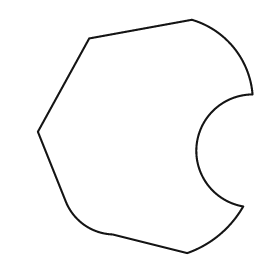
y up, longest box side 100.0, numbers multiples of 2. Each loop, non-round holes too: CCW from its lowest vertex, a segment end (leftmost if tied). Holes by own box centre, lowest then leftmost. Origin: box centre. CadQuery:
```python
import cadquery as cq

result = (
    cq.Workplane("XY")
    .moveTo(18.0, -50.0)
    .threePointArc((32.0, -42.0), (42.0, -30.0))
    .threePointArc((22.0, -4.0), (46.0, 18.0))
    .threePointArc((38.0, 38.0), (20.0, 50.0))
    .lineTo(-24.0, 42.0)
    .lineTo(-46.0, 2.0)
    .lineTo(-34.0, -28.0)
    .threePointArc((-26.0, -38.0), (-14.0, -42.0))
    .close()
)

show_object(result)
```